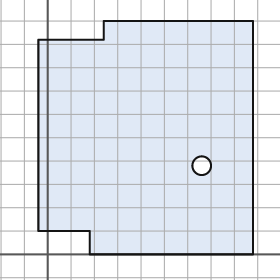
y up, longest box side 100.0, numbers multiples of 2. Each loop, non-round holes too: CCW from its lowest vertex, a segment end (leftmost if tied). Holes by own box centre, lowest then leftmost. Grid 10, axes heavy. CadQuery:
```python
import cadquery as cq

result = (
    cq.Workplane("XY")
    .moveTo(18.0, 0.0)
    .lineTo(88.0, 0.0)
    .lineTo(88.0, 100.0)
    .lineTo(24.0, 100.0)
    .lineTo(24.0, 92.0)
    .lineTo(-4.0, 92.0)
    .lineTo(-4.0, 10.0)
    .lineTo(18.0, 10.0)
    .close()
    .moveTo(66.0, 38.0)
    .circle(4.0)
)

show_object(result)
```